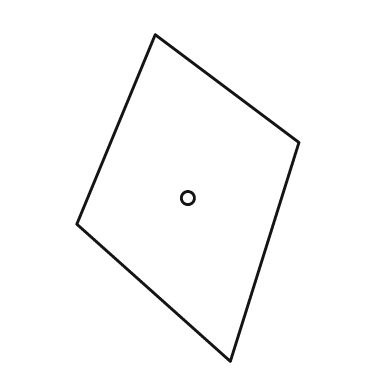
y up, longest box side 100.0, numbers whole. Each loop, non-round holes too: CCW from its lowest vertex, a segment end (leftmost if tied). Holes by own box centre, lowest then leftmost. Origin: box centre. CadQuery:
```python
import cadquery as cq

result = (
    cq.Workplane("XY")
    .moveTo(13.0, -50.0)
    .lineTo(34.0, 17.0)
    .lineTo(-10.0, 50.0)
    .lineTo(-34.0, -8.0)
    .close()
    .moveTo(0.0, 0.0)
    .circle(2.0)
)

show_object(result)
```